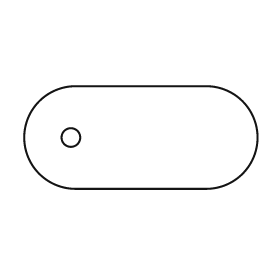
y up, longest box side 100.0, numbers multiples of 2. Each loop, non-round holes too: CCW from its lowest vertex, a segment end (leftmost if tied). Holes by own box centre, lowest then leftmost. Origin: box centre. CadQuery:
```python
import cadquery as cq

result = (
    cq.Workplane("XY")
    .moveTo(-28.0, -22.0)
    .lineTo(28.0, -22.0)
    .threePointArc((50.0, 0.0), (28.0, 22.0))
    .lineTo(-28.0, 22.0)
    .threePointArc((-50.0, 0.0), (-28.0, -22.0))
    .close()
    .moveTo(-30.0, 0.0)
    .circle(4.0)
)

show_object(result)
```